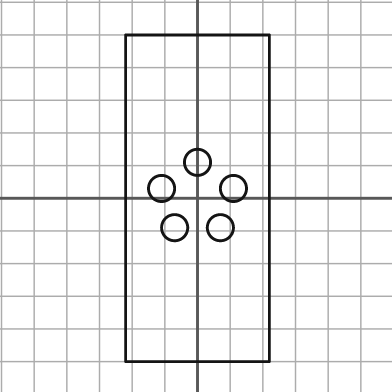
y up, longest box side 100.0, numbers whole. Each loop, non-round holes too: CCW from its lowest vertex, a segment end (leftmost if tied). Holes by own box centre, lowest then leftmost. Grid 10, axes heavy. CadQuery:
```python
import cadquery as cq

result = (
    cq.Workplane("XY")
    .moveTo(-22.0, -50.0)
    .lineTo(22.0, -50.0)
    .lineTo(22.0, 50.0)
    .lineTo(-22.0, 50.0)
    .close()
    .moveTo(-7.0, -9.0)
    .circle(4.0)
    .moveTo(7.0, -9.0)
    .circle(4.0)
    .moveTo(-11.0, 3.0)
    .circle(4.0)
    .moveTo(11.0, 3.0)
    .circle(4.0)
    .moveTo(0.0, 11.0)
    .circle(4.0)
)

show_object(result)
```